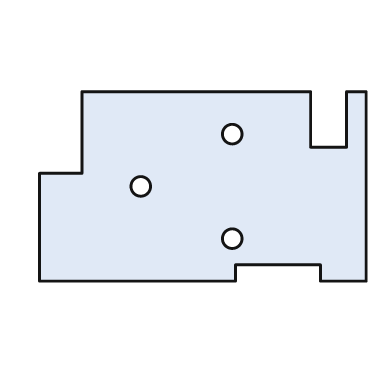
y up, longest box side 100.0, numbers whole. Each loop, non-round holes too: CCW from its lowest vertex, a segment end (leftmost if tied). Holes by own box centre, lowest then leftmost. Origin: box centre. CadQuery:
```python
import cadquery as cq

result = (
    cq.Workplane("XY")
    .moveTo(-50.0, -29.0)
    .lineTo(10.0, -29.0)
    .lineTo(10.0, -24.0)
    .lineTo(36.0, -24.0)
    .lineTo(36.0, -29.0)
    .lineTo(50.0, -29.0)
    .lineTo(50.0, 29.0)
    .lineTo(44.0, 29.0)
    .lineTo(44.0, 12.0)
    .lineTo(33.0, 12.0)
    .lineTo(33.0, 29.0)
    .lineTo(-37.0, 29.0)
    .lineTo(-37.0, 4.0)
    .lineTo(-50.0, 4.0)
    .close()
    .moveTo(9.0, -16.0)
    .circle(3.0)
    .moveTo(-19.0, 0.0)
    .circle(3.0)
    .moveTo(9.0, 16.0)
    .circle(3.0)
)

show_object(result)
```